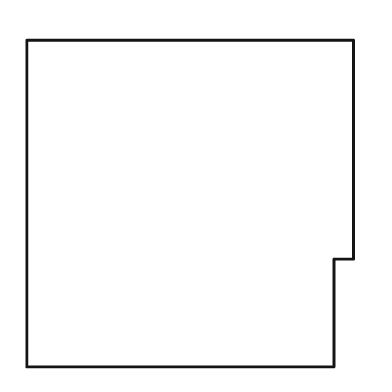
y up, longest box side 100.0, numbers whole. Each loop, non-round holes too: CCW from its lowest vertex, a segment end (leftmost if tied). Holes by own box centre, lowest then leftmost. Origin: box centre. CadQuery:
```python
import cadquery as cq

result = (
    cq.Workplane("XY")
    .moveTo(-50.0, -50.0)
    .lineTo(44.0, -50.0)
    .lineTo(44.0, -17.0)
    .lineTo(50.0, -17.0)
    .lineTo(50.0, 50.0)
    .lineTo(-50.0, 50.0)
    .close()
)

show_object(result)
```